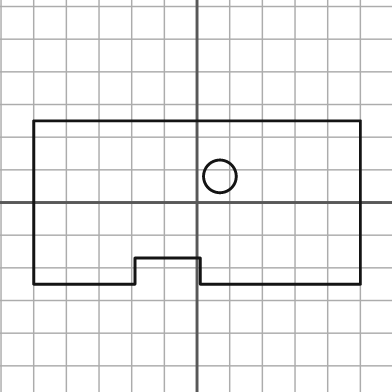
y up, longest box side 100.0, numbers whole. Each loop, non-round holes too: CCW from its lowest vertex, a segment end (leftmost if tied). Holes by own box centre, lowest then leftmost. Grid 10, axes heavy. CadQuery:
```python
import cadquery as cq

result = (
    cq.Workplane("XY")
    .moveTo(-50.0, -25.0)
    .lineTo(-19.0, -25.0)
    .lineTo(-19.0, -17.0)
    .lineTo(1.0, -17.0)
    .lineTo(1.0, -25.0)
    .lineTo(50.0, -25.0)
    .lineTo(50.0, 25.0)
    .lineTo(-50.0, 25.0)
    .close()
    .moveTo(7.0, 8.0)
    .circle(5.0)
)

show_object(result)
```